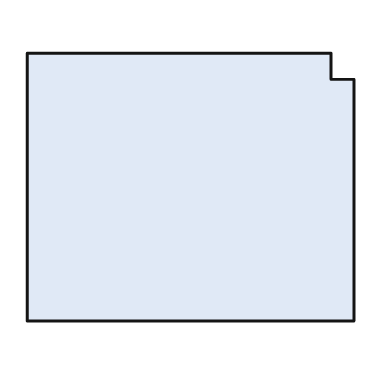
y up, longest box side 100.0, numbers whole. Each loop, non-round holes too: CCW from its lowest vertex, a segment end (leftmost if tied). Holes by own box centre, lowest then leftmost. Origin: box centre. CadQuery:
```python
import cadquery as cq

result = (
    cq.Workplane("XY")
    .moveTo(-50.0, -41.0)
    .lineTo(50.0, -41.0)
    .lineTo(50.0, 33.0)
    .lineTo(43.0, 33.0)
    .lineTo(43.0, 41.0)
    .lineTo(-50.0, 41.0)
    .close()
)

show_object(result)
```